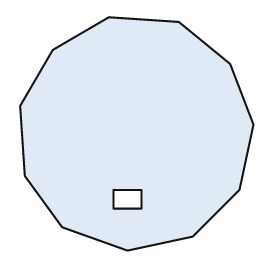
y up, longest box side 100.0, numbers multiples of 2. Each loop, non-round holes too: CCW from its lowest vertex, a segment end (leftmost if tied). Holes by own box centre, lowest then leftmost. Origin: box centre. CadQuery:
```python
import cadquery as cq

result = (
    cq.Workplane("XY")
    .moveTo(-4.0, -50.0)
    .lineTo(24.0, -44.0)
    .lineTo(44.0, -24.0)
    .lineTo(50.0, 4.0)
    .lineTo(40.0, 30.0)
    .lineTo(18.0, 48.0)
    .lineTo(-12.0, 50.0)
    .lineTo(-36.0, 36.0)
    .lineTo(-50.0, 12.0)
    .lineTo(-48.0, -18.0)
    .lineTo(-32.0, -40.0)
    .close()
    .moveTo(-10.0, -32.0)
    .lineTo(2.0, -32.0)
    .lineTo(2.0, -24.0)
    .lineTo(-10.0, -24.0)
    .close()
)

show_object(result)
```